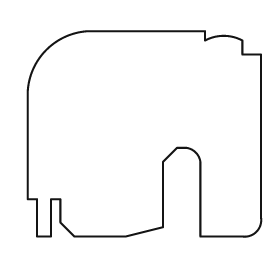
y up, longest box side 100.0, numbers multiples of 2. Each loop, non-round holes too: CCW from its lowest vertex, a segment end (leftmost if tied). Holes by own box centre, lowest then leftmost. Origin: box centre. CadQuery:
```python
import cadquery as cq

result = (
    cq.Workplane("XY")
    .moveTo(-46.0, -44.0)
    .lineTo(-40.0, -44.0)
    .lineTo(-40.0, -28.0)
    .lineTo(-36.0, -28.0)
    .lineTo(-36.0, -38.0)
    .lineTo(-30.0, -44.0)
    .lineTo(-8.0, -44.0)
    .lineTo(8.0, -40.0)
    .lineTo(8.0, -12.0)
    .lineTo(14.0, -6.0)
    .lineTo(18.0, -6.0)
    .threePointArc((22.0, -8.0), (24.0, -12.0))
    .lineTo(24.0, -44.0)
    .lineTo(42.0, -44.0)
    .threePointArc((48.0, -42.0), (50.0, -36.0))
    .lineTo(50.0, 34.0)
    .lineTo(42.0, 34.0)
    .lineTo(42.0, 40.0)
    .threePointArc((34.0, 42.0), (26.0, 40.0))
    .lineTo(26.0, 44.0)
    .lineTo(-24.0, 44.0)
    .threePointArc((-42.0, 36.0), (-50.0, 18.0))
    .lineTo(-50.0, -28.0)
    .lineTo(-46.0, -28.0)
    .close()
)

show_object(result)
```